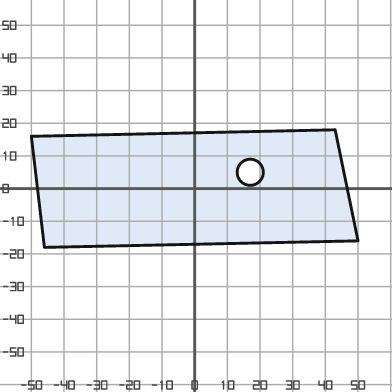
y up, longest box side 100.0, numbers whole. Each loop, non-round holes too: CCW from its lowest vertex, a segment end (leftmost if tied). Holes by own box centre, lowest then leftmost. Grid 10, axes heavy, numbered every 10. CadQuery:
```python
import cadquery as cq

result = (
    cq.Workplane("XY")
    .moveTo(-46.0, -18.0)
    .lineTo(50.0, -16.0)
    .lineTo(43.0, 18.0)
    .lineTo(-50.0, 16.0)
    .close()
    .moveTo(17.0, 5.0)
    .circle(4.0)
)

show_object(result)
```